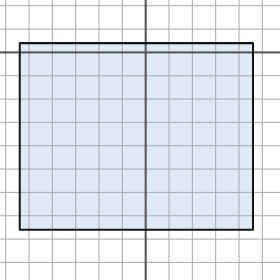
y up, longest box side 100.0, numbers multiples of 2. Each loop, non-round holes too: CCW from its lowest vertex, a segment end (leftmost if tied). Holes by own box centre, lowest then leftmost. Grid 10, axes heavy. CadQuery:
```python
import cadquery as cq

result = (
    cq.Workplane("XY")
    .moveTo(-54.0, -76.0)
    .lineTo(46.0, -76.0)
    .lineTo(46.0, 4.0)
    .lineTo(-54.0, 4.0)
    .close()
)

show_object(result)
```